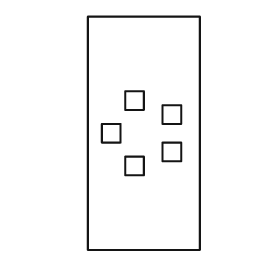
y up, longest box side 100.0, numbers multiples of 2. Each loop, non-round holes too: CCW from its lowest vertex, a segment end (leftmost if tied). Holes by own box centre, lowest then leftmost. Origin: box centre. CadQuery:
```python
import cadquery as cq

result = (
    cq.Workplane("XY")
    .moveTo(-24.0, -50.0)
    .lineTo(24.0, -50.0)
    .lineTo(24.0, 50.0)
    .lineTo(-24.0, 50.0)
    .close()
    .moveTo(-8.0, -18.0)
    .lineTo(0.0, -18.0)
    .lineTo(0.0, -10.0)
    .lineTo(-8.0, -10.0)
    .close()
    .moveTo(8.0, -12.0)
    .lineTo(16.0, -12.0)
    .lineTo(16.0, -4.0)
    .lineTo(8.0, -4.0)
    .close()
    .moveTo(-18.0, -4.0)
    .lineTo(-10.0, -4.0)
    .lineTo(-10.0, 4.0)
    .lineTo(-18.0, 4.0)
    .close()
    .moveTo(8.0, 4.0)
    .lineTo(16.0, 4.0)
    .lineTo(16.0, 12.0)
    .lineTo(8.0, 12.0)
    .close()
    .moveTo(-8.0, 10.0)
    .lineTo(0.0, 10.0)
    .lineTo(0.0, 18.0)
    .lineTo(-8.0, 18.0)
    .close()
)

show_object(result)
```